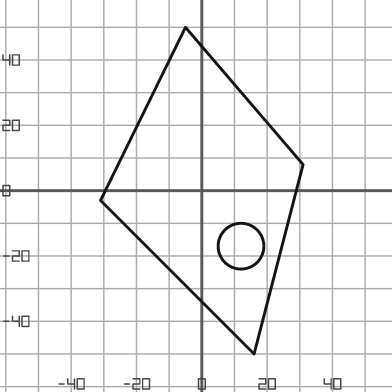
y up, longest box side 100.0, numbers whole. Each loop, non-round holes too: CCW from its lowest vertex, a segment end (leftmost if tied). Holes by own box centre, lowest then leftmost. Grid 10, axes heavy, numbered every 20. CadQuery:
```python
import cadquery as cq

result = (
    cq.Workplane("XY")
    .moveTo(16.0, -50.0)
    .lineTo(31.0, 8.0)
    .lineTo(-5.0, 50.0)
    .lineTo(-31.0, -3.0)
    .close()
    .moveTo(12.0, -17.0)
    .circle(7.0)
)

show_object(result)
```